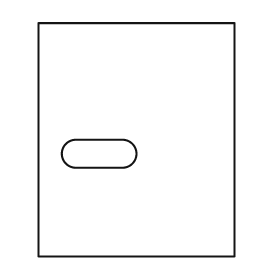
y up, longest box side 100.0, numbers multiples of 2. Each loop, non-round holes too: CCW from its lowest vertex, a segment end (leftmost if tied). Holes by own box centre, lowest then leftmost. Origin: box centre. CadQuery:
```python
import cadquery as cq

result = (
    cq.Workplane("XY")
    .moveTo(-42.0, -50.0)
    .lineTo(42.0, -50.0)
    .lineTo(42.0, 50.0)
    .lineTo(-42.0, 50.0)
    .close()
    .moveTo(-26.0, -12.0)
    .lineTo(-6.0, -12.0)
    .threePointArc((0.0, -6.0), (-6.0, 0.0))
    .lineTo(-26.0, 0.0)
    .threePointArc((-32.0, -6.0), (-26.0, -12.0))
    .close()
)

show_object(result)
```